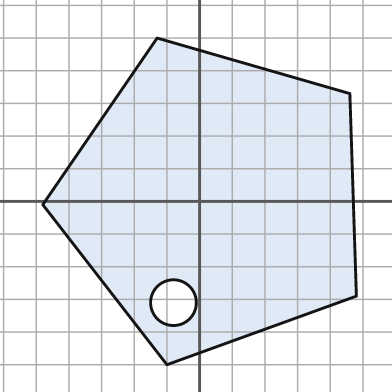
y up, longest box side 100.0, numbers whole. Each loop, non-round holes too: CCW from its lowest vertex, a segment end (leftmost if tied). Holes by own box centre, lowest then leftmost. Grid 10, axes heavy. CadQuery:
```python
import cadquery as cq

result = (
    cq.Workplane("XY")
    .moveTo(-10.0, -50.0)
    .lineTo(48.0, -29.0)
    .lineTo(46.0, 33.0)
    .lineTo(-13.0, 50.0)
    .lineTo(-48.0, -1.0)
    .close()
    .moveTo(-8.0, -31.0)
    .circle(7.0)
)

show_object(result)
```